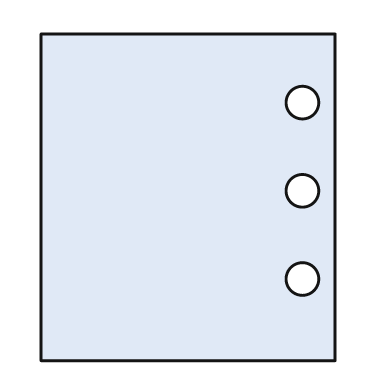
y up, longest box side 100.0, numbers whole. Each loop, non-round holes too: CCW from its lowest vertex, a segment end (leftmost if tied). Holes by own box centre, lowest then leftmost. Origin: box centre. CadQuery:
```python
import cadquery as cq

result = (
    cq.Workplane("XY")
    .moveTo(-45.0, -50.0)
    .lineTo(45.0, -50.0)
    .lineTo(45.0, 50.0)
    .lineTo(-45.0, 50.0)
    .close()
    .moveTo(35.0, -25.0)
    .circle(5.0)
    .moveTo(35.0, 2.0)
    .circle(5.0)
    .moveTo(35.0, 29.0)
    .circle(5.0)
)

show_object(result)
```